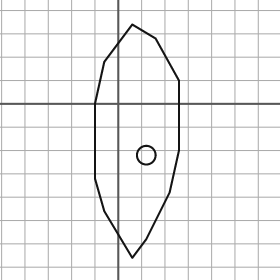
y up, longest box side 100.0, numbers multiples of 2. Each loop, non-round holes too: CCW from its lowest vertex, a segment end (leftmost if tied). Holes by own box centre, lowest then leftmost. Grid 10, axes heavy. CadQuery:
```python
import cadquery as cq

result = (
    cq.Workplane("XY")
    .moveTo(6.0, -66.0)
    .lineTo(12.0, -58.0)
    .lineTo(22.0, -38.0)
    .lineTo(26.0, -20.0)
    .lineTo(26.0, 10.0)
    .lineTo(16.0, 28.0)
    .lineTo(6.0, 34.0)
    .lineTo(-6.0, 18.0)
    .lineTo(-10.0, 0.0)
    .lineTo(-10.0, -32.0)
    .lineTo(-6.0, -46.0)
    .close()
    .moveTo(12.0, -22.0)
    .circle(4.0)
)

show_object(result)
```